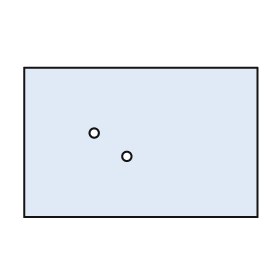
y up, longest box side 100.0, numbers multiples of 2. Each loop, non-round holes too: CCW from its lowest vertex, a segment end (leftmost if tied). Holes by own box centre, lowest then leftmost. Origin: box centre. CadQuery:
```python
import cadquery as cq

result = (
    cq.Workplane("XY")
    .moveTo(-50.0, -32.0)
    .lineTo(50.0, -32.0)
    .lineTo(50.0, 32.0)
    .lineTo(-50.0, 32.0)
    .close()
    .moveTo(-6.0, -6.0)
    .circle(2.0)
    .moveTo(-20.0, 4.0)
    .circle(2.0)
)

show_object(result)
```